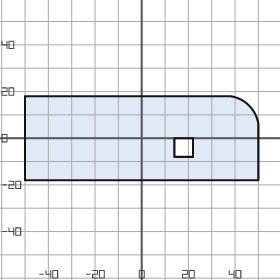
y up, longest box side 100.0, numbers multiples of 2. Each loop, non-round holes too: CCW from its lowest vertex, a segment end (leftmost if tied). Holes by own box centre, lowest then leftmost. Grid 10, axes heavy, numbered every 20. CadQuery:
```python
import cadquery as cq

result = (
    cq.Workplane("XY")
    .moveTo(-50.0, -18.0)
    .lineTo(50.0, -18.0)
    .lineTo(50.0, 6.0)
    .threePointArc((46.0, 14.0), (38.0, 18.0))
    .lineTo(-50.0, 18.0)
    .close()
    .moveTo(14.0, -8.0)
    .lineTo(22.0, -8.0)
    .lineTo(22.0, 0.0)
    .lineTo(14.0, 0.0)
    .close()
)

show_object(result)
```